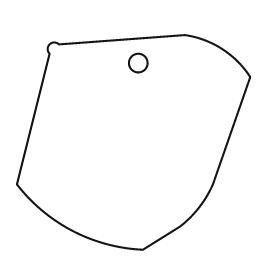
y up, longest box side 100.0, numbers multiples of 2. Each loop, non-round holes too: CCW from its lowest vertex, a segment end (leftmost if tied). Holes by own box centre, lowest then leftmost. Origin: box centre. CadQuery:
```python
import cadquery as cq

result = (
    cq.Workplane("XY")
    .moveTo(4.0, -46.0)
    .lineTo(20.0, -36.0)
    .threePointArc((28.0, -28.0), (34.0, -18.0))
    .lineTo(50.0, 28.0)
    .threePointArc((38.0, 40.0), (22.0, 46.0))
    .lineTo(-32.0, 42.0)
    .threePointArc((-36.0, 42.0), (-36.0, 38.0))
    .lineTo(-50.0, -18.0)
    .threePointArc((-26.0, -38.0), (4.0, -46.0))
    .close()
    .moveTo(2.0, 34.0)
    .circle(4.0)
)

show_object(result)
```